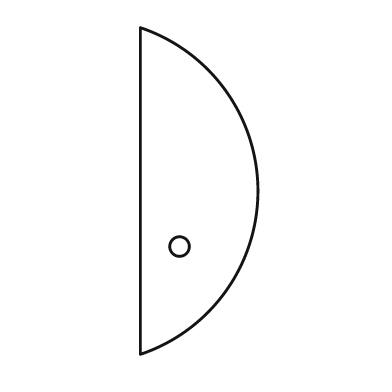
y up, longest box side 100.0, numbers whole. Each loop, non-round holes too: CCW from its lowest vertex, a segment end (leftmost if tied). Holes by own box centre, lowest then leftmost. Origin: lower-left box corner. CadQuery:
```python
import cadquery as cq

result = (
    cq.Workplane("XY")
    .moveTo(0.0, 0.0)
    .threePointArc((36.0, 50.0), (0.0, 100.0))
    .close()
    .moveTo(12.0, 33.0)
    .circle(3.0)
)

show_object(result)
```